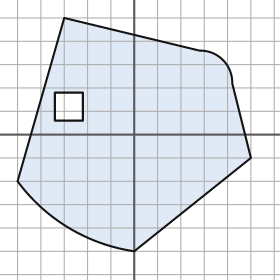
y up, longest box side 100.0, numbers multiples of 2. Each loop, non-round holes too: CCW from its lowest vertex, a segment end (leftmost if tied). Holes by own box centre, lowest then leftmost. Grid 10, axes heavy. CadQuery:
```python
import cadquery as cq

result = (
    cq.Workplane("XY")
    .moveTo(0.0, -50.0)
    .lineTo(50.0, -10.0)
    .lineTo(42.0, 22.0)
    .threePointArc((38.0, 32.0), (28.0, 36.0))
    .lineTo(-30.0, 50.0)
    .lineTo(-50.0, -20.0)
    .threePointArc((-28.0, -40.0), (0.0, -50.0))
    .close()
    .moveTo(-34.0, 6.0)
    .lineTo(-22.0, 6.0)
    .lineTo(-22.0, 18.0)
    .lineTo(-34.0, 18.0)
    .close()
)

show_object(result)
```